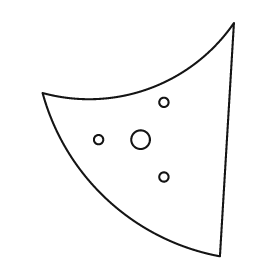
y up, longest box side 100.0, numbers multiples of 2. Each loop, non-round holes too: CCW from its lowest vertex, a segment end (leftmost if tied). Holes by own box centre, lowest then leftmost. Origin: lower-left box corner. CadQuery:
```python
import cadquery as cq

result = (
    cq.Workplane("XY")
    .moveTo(76.0, 0.0)
    .lineTo(82.0, 100.0)
    .threePointArc((46.0, 72.0), (0.0, 70.0))
    .threePointArc((28.0, 24.0), (76.0, 0.0))
    .close()
    .moveTo(52.0, 34.0)
    .circle(2.0)
    .moveTo(24.0, 50.0)
    .circle(2.0)
    .moveTo(42.0, 50.0)
    .circle(4.0)
    .moveTo(52.0, 66.0)
    .circle(2.0)
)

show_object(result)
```